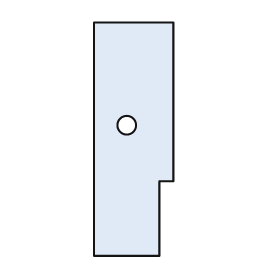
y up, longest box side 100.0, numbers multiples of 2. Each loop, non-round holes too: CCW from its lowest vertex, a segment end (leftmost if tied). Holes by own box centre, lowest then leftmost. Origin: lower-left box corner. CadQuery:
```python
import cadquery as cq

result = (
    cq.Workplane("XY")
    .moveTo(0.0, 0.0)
    .lineTo(28.0, 0.0)
    .lineTo(28.0, 32.0)
    .lineTo(34.0, 32.0)
    .lineTo(34.0, 100.0)
    .lineTo(0.0, 100.0)
    .close()
    .moveTo(14.0, 56.0)
    .circle(4.0)
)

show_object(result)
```